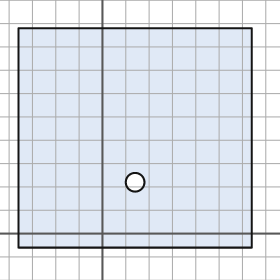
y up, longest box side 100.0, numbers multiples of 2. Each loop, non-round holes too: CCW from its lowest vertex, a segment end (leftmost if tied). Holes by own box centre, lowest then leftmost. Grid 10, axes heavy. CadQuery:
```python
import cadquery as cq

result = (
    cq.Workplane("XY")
    .moveTo(-36.0, -6.0)
    .lineTo(64.0, -6.0)
    .lineTo(64.0, 88.0)
    .lineTo(-36.0, 88.0)
    .close()
    .moveTo(14.0, 22.0)
    .circle(4.0)
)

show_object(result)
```